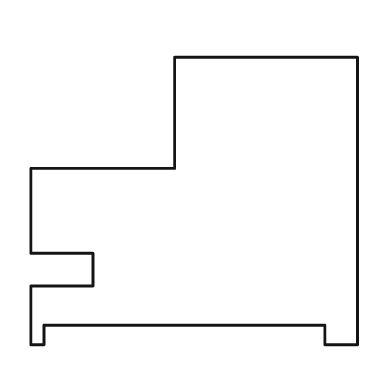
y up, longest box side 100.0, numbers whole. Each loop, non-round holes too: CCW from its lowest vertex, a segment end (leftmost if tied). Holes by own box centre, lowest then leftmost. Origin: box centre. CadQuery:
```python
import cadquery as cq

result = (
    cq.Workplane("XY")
    .moveTo(-50.0, -44.0)
    .lineTo(-46.0, -44.0)
    .lineTo(-46.0, -38.0)
    .lineTo(40.0, -38.0)
    .lineTo(40.0, -44.0)
    .lineTo(50.0, -44.0)
    .lineTo(50.0, 44.0)
    .lineTo(-6.0, 44.0)
    .lineTo(-6.0, 10.0)
    .lineTo(-50.0, 10.0)
    .lineTo(-50.0, -16.0)
    .lineTo(-31.0, -16.0)
    .lineTo(-31.0, -26.0)
    .lineTo(-50.0, -26.0)
    .close()
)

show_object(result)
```